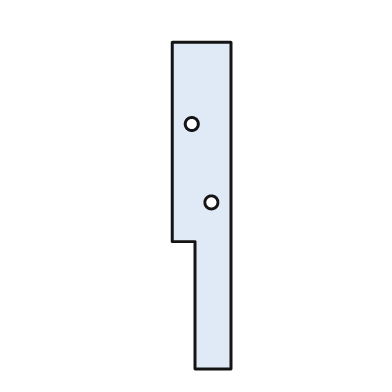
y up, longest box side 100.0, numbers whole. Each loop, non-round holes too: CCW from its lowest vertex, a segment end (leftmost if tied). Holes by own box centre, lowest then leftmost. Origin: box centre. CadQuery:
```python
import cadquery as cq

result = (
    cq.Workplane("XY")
    .moveTo(-2.0, -50.0)
    .lineTo(9.0, -50.0)
    .lineTo(9.0, 50.0)
    .lineTo(-9.0, 50.0)
    .lineTo(-9.0, -11.0)
    .lineTo(-2.0, -11.0)
    .close()
    .moveTo(3.0, 1.0)
    .circle(2.0)
    .moveTo(-3.0, 25.0)
    .circle(2.0)
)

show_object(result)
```